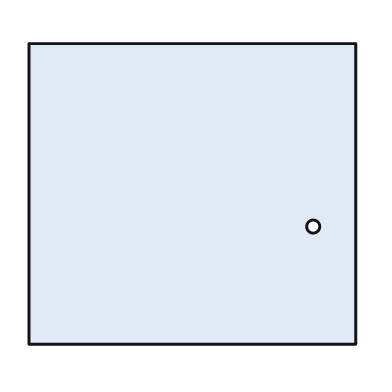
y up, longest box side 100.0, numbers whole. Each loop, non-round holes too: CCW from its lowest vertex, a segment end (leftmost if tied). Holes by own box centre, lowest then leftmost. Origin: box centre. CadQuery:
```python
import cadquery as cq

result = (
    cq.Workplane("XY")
    .moveTo(-50.0, -46.0)
    .lineTo(50.0, -46.0)
    .lineTo(50.0, 46.0)
    .lineTo(-50.0, 46.0)
    .close()
    .moveTo(37.0, -10.0)
    .circle(2.0)
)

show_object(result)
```